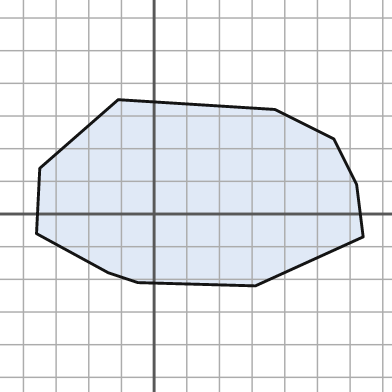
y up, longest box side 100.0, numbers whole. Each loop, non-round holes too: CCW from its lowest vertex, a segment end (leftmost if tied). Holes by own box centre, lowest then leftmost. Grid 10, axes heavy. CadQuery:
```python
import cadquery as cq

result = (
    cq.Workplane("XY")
    .moveTo(31.0, -22.0)
    .lineTo(64.0, -7.0)
    .lineTo(62.0, 9.0)
    .lineTo(55.0, 23.0)
    .lineTo(37.0, 32.0)
    .lineTo(-11.0, 35.0)
    .lineTo(-35.0, 14.0)
    .lineTo(-36.0, -6.0)
    .lineTo(-14.0, -18.0)
    .lineTo(-5.0, -21.0)
    .close()
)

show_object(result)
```